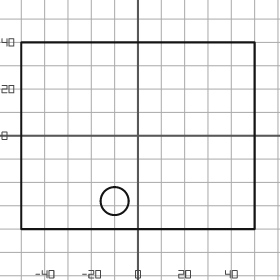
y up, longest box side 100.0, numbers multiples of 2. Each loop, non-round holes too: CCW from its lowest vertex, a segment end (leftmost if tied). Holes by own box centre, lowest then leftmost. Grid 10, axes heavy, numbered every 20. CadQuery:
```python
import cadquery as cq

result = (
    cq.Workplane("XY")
    .moveTo(-50.0, -40.0)
    .lineTo(50.0, -40.0)
    .lineTo(50.0, 40.0)
    .lineTo(-50.0, 40.0)
    .close()
    .moveTo(-10.0, -28.0)
    .circle(6.0)
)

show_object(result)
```